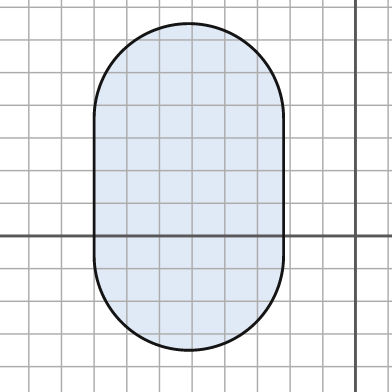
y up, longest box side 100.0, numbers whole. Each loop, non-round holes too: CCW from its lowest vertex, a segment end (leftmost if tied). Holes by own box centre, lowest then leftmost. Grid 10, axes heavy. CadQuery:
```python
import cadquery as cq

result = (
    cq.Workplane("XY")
    .moveTo(-80.0, -6.0)
    .threePointArc((-51.0, -35.0), (-22.0, -6.0))
    .lineTo(-22.0, 36.0)
    .threePointArc((-51.0, 65.0), (-80.0, 36.0))
    .close()
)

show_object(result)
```